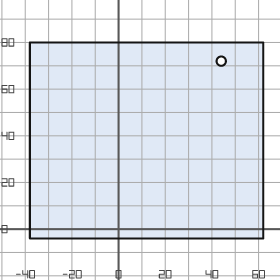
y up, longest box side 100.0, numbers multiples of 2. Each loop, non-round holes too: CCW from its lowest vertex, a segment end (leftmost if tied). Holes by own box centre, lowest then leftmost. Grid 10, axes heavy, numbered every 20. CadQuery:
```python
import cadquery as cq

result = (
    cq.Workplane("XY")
    .moveTo(-38.0, -4.0)
    .lineTo(62.0, -4.0)
    .lineTo(62.0, 80.0)
    .lineTo(-38.0, 80.0)
    .close()
    .moveTo(44.0, 72.0)
    .circle(2.0)
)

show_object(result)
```